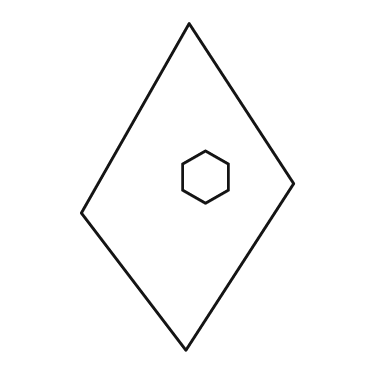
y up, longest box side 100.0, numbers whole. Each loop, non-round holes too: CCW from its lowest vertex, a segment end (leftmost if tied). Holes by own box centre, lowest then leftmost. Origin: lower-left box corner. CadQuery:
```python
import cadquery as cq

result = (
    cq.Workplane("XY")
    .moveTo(32.0, 0.0)
    .lineTo(65.0, 51.0)
    .lineTo(33.0, 100.0)
    .lineTo(0.0, 42.0)
    .close()
    .moveTo(38.0, 45.0)
    .lineTo(45.0, 49.0)
    .lineTo(45.0, 57.0)
    .lineTo(38.0, 61.0)
    .lineTo(31.0, 57.0)
    .lineTo(31.0, 49.0)
    .close()
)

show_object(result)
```